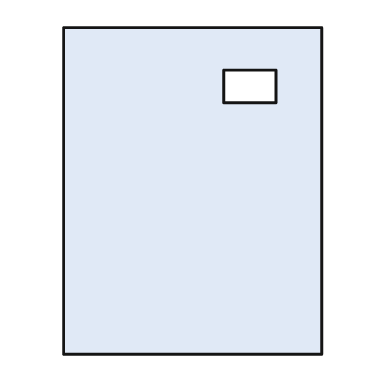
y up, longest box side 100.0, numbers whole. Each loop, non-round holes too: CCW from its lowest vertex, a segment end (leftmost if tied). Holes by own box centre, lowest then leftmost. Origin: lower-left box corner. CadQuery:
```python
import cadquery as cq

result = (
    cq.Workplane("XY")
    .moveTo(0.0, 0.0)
    .lineTo(79.0, 0.0)
    .lineTo(79.0, 100.0)
    .lineTo(0.0, 100.0)
    .close()
    .moveTo(49.0, 77.0)
    .lineTo(65.0, 77.0)
    .lineTo(65.0, 87.0)
    .lineTo(49.0, 87.0)
    .close()
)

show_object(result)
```